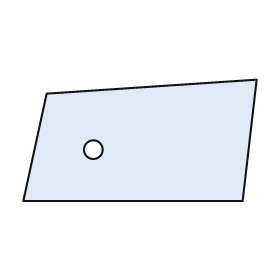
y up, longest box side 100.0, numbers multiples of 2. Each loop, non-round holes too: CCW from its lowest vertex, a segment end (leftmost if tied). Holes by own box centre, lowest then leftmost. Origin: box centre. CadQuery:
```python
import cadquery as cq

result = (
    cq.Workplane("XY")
    .moveTo(-50.0, -26.0)
    .lineTo(44.0, -26.0)
    .lineTo(50.0, 26.0)
    .lineTo(-40.0, 20.0)
    .close()
    .moveTo(-20.0, -4.0)
    .circle(4.0)
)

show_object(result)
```